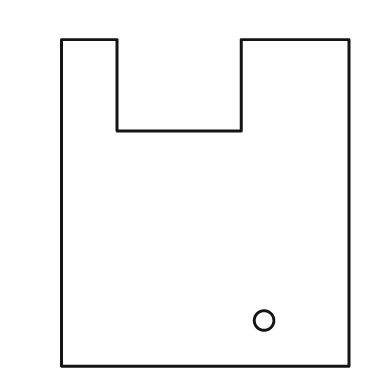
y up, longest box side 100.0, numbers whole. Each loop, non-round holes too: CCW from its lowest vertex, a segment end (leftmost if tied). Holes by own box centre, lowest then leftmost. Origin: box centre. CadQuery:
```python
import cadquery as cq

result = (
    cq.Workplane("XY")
    .moveTo(-44.0, -50.0)
    .lineTo(44.0, -50.0)
    .lineTo(44.0, 50.0)
    .lineTo(11.0, 50.0)
    .lineTo(11.0, 22.0)
    .lineTo(-27.0, 22.0)
    .lineTo(-27.0, 50.0)
    .lineTo(-44.0, 50.0)
    .close()
    .moveTo(18.0, -36.0)
    .circle(3.0)
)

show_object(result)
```